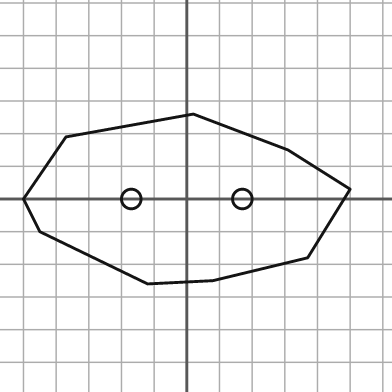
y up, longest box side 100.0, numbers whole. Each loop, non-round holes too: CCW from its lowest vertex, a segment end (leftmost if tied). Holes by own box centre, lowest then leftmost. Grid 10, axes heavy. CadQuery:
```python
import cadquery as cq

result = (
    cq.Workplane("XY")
    .moveTo(-12.0, -26.0)
    .lineTo(8.0, -25.0)
    .lineTo(37.0, -18.0)
    .lineTo(50.0, 3.0)
    .lineTo(31.0, 15.0)
    .lineTo(2.0, 26.0)
    .lineTo(-37.0, 19.0)
    .lineTo(-50.0, 0.0)
    .lineTo(-45.0, -10.0)
    .close()
    .moveTo(-17.0, 0.0)
    .circle(3.0)
    .moveTo(17.0, 0.0)
    .circle(3.0)
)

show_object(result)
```